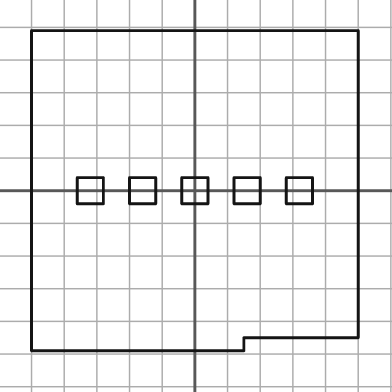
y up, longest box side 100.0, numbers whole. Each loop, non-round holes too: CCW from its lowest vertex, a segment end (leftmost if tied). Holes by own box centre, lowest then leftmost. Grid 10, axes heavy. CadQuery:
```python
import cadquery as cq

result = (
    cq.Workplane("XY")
    .moveTo(-50.0, -49.0)
    .lineTo(15.0, -49.0)
    .lineTo(15.0, -45.0)
    .lineTo(50.0, -45.0)
    .lineTo(50.0, 49.0)
    .lineTo(-50.0, 49.0)
    .close()
    .moveTo(-36.0, -4.0)
    .lineTo(-28.0, -4.0)
    .lineTo(-28.0, 4.0)
    .lineTo(-36.0, 4.0)
    .close()
    .moveTo(-20.0, -4.0)
    .lineTo(-12.0, -4.0)
    .lineTo(-12.0, 4.0)
    .lineTo(-20.0, 4.0)
    .close()
    .moveTo(-4.0, -4.0)
    .lineTo(4.0, -4.0)
    .lineTo(4.0, 4.0)
    .lineTo(-4.0, 4.0)
    .close()
    .moveTo(12.0, -4.0)
    .lineTo(20.0, -4.0)
    .lineTo(20.0, 4.0)
    .lineTo(12.0, 4.0)
    .close()
    .moveTo(28.0, -4.0)
    .lineTo(36.0, -4.0)
    .lineTo(36.0, 4.0)
    .lineTo(28.0, 4.0)
    .close()
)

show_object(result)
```